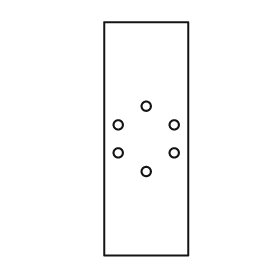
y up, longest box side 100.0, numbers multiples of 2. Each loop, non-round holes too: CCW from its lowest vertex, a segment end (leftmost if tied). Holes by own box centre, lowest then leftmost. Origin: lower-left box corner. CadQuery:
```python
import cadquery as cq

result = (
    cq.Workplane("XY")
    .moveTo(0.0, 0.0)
    .lineTo(36.0, 0.0)
    .lineTo(36.0, 100.0)
    .lineTo(0.0, 100.0)
    .close()
    .moveTo(18.0, 36.0)
    .circle(2.0)
    .moveTo(6.0, 44.0)
    .circle(2.0)
    .moveTo(30.0, 44.0)
    .circle(2.0)
    .moveTo(6.0, 56.0)
    .circle(2.0)
    .moveTo(30.0, 56.0)
    .circle(2.0)
    .moveTo(18.0, 64.0)
    .circle(2.0)
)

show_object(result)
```